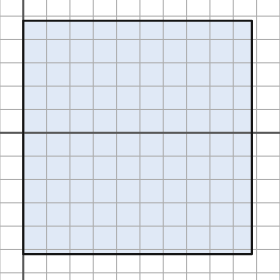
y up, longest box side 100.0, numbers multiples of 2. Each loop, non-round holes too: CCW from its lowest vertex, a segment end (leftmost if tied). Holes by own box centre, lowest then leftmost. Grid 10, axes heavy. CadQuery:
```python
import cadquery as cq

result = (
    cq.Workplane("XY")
    .moveTo(0.0, -52.0)
    .lineTo(98.0, -52.0)
    .lineTo(98.0, 48.0)
    .lineTo(0.0, 48.0)
    .close()
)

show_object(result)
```